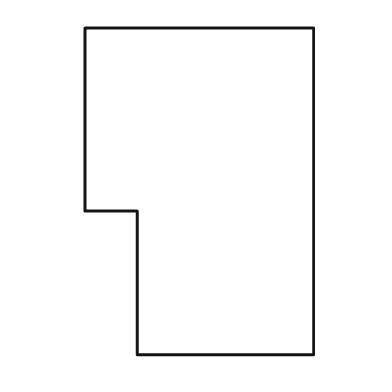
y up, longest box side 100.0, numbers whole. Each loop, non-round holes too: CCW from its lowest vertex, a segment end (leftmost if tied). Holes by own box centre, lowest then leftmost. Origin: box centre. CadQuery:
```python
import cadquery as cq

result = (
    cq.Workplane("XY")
    .moveTo(-19.0, -50.0)
    .lineTo(35.0, -50.0)
    .lineTo(35.0, 50.0)
    .lineTo(-35.0, 50.0)
    .lineTo(-35.0, -6.0)
    .lineTo(-19.0, -6.0)
    .close()
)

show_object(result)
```